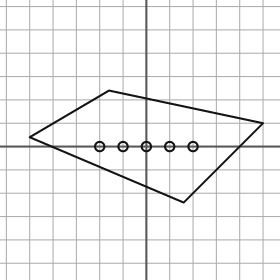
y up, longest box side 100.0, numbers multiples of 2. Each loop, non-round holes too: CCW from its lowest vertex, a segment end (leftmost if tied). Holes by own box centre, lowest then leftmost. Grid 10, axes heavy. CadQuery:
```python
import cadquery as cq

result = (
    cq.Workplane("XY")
    .moveTo(16.0, -24.0)
    .lineTo(50.0, 10.0)
    .lineTo(-16.0, 24.0)
    .lineTo(-50.0, 4.0)
    .close()
    .moveTo(-20.0, 0.0)
    .circle(2.0)
    .moveTo(-10.0, 0.0)
    .circle(2.0)
    .moveTo(0.0, 0.0)
    .circle(2.0)
    .moveTo(10.0, 0.0)
    .circle(2.0)
    .moveTo(20.0, 0.0)
    .circle(2.0)
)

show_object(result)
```